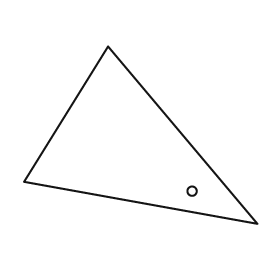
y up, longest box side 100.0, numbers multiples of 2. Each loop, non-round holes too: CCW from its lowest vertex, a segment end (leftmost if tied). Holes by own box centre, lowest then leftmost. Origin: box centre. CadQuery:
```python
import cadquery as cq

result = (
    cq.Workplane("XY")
    .moveTo(50.0, -38.0)
    .lineTo(-14.0, 38.0)
    .lineTo(-50.0, -20.0)
    .close()
    .moveTo(22.0, -24.0)
    .circle(2.0)
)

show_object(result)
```